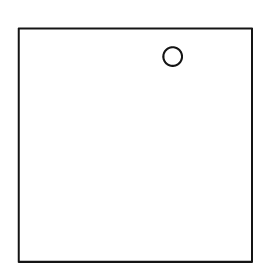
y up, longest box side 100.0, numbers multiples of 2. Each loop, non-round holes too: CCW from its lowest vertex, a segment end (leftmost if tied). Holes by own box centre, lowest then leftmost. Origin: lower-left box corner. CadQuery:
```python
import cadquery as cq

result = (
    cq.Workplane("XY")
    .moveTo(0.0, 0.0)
    .lineTo(100.0, 0.0)
    .lineTo(100.0, 100.0)
    .lineTo(0.0, 100.0)
    .close()
    .moveTo(66.0, 88.0)
    .circle(4.0)
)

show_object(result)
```